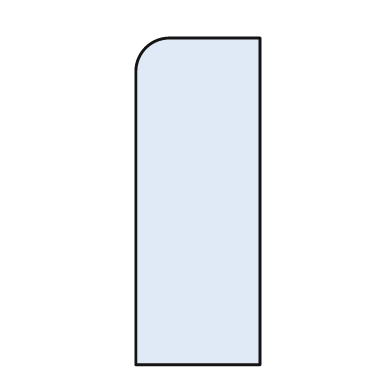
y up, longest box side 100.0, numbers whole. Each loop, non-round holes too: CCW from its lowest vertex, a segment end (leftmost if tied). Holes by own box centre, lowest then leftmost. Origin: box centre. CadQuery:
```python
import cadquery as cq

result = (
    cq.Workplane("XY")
    .moveTo(-19.0, -50.0)
    .lineTo(19.0, -50.0)
    .lineTo(19.0, 50.0)
    .lineTo(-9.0, 50.0)
    .threePointArc((-16.0, 47.0), (-19.0, 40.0))
    .close()
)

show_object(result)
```